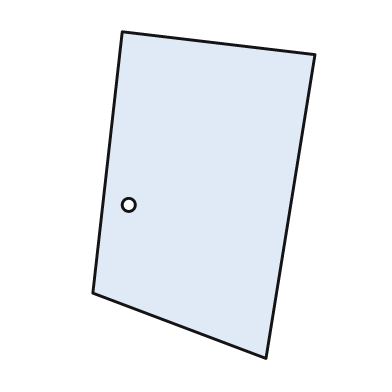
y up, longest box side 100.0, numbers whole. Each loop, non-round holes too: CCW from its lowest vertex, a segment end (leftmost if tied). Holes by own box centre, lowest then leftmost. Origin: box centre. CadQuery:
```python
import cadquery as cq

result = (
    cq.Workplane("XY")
    .moveTo(19.0, -50.0)
    .lineTo(34.0, 43.0)
    .lineTo(-25.0, 50.0)
    .lineTo(-34.0, -30.0)
    .close()
    .moveTo(-23.0, -3.0)
    .circle(2.0)
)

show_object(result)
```